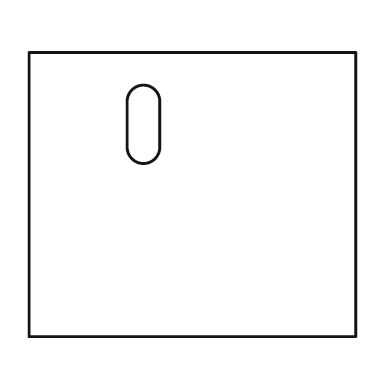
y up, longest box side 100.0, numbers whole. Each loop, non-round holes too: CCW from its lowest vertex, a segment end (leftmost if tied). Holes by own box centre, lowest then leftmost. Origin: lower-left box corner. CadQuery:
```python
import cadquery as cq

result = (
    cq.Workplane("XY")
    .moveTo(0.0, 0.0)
    .lineTo(100.0, 0.0)
    .lineTo(100.0, 87.0)
    .lineTo(0.0, 87.0)
    .close()
    .moveTo(30.0, 58.0)
    .threePointArc((35.0, 53.0), (40.0, 58.0))
    .lineTo(40.0, 72.0)
    .threePointArc((35.0, 77.0), (30.0, 72.0))
    .close()
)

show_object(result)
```